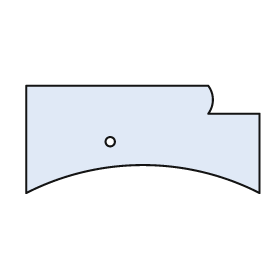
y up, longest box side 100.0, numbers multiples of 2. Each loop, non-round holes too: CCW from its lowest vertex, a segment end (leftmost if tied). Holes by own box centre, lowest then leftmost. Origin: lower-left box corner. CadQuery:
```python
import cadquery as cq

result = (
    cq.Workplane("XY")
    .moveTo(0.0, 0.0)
    .threePointArc((50.0, 12.0), (100.0, 0.0))
    .lineTo(100.0, 34.0)
    .lineTo(78.0, 34.0)
    .threePointArc((80.0, 40.0), (78.0, 46.0))
    .lineTo(0.0, 46.0)
    .close()
    .moveTo(36.0, 22.0)
    .circle(2.0)
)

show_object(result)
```